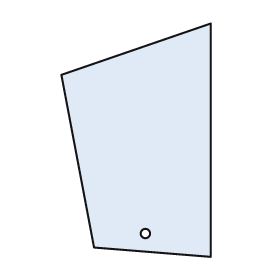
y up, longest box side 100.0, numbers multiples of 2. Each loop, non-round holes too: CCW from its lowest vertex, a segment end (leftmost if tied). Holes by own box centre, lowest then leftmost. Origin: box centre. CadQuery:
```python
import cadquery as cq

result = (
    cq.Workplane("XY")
    .moveTo(32.0, -50.0)
    .lineTo(32.0, 50.0)
    .lineTo(-32.0, 28.0)
    .lineTo(-18.0, -46.0)
    .close()
    .moveTo(4.0, -40.0)
    .circle(2.0)
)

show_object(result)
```